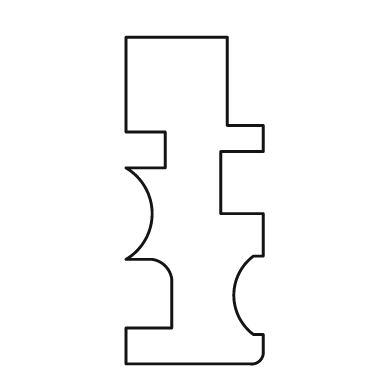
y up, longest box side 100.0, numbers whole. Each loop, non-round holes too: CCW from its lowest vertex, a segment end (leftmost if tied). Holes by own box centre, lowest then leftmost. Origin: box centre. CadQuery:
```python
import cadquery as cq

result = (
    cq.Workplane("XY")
    .moveTo(-21.0, -50.0)
    .lineTo(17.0, -50.0)
    .threePointArc((20.0, -49.0), (21.0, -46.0))
    .lineTo(21.0, -41.0)
    .lineTo(18.0, -41.0)
    .threePointArc((12.0, -29.0), (18.0, -17.0))
    .lineTo(21.0, -17.0)
    .lineTo(21.0, -4.0)
    .lineTo(8.0, -4.0)
    .lineTo(8.0, 15.0)
    .lineTo(21.0, 15.0)
    .lineTo(21.0, 23.0)
    .lineTo(10.0, 23.0)
    .lineTo(10.0, 50.0)
    .lineTo(-21.0, 50.0)
    .lineTo(-21.0, 21.0)
    .lineTo(-9.0, 21.0)
    .lineTo(-9.0, 10.0)
    .lineTo(-21.0, 10.0)
    .threePointArc((-13.0, -4.0), (-21.0, -18.0))
    .lineTo(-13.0, -18.0)
    .threePointArc((-9.0, -20.0), (-7.0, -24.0))
    .lineTo(-7.0, -39.0)
    .lineTo(-21.0, -39.0)
    .close()
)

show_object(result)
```